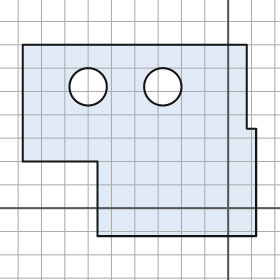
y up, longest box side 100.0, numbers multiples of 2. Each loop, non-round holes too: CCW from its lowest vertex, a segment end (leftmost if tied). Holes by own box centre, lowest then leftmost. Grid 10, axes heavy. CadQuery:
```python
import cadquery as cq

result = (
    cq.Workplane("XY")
    .moveTo(-56.0, -12.0)
    .lineTo(12.0, -12.0)
    .lineTo(12.0, 34.0)
    .lineTo(8.0, 34.0)
    .lineTo(8.0, 70.0)
    .lineTo(-88.0, 70.0)
    .lineTo(-88.0, 20.0)
    .lineTo(-56.0, 20.0)
    .close()
    .moveTo(-60.0, 52.0)
    .circle(8.0)
    .moveTo(-28.0, 52.0)
    .circle(8.0)
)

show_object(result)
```